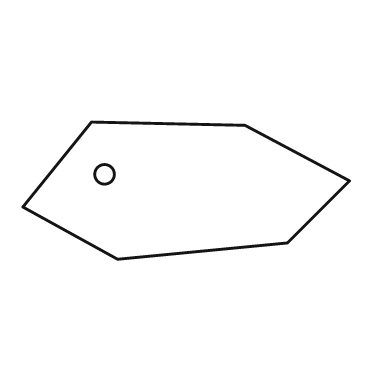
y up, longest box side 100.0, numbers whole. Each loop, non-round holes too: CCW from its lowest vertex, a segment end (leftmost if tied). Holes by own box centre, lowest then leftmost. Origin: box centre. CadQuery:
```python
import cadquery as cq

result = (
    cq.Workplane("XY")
    .moveTo(-21.0, -21.0)
    .lineTo(31.0, -16.0)
    .lineTo(50.0, 3.0)
    .lineTo(18.0, 20.0)
    .lineTo(-29.0, 21.0)
    .lineTo(-50.0, -5.0)
    .close()
    .moveTo(-25.0, 5.0)
    .circle(3.0)
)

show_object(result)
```